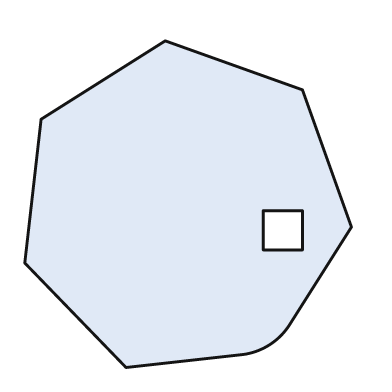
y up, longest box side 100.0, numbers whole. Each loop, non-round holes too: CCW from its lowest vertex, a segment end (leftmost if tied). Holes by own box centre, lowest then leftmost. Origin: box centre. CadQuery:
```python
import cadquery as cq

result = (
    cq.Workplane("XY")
    .moveTo(-19.0, -50.0)
    .lineTo(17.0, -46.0)
    .threePointArc((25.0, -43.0), (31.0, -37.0))
    .lineTo(50.0, -7.0)
    .lineTo(35.0, 35.0)
    .lineTo(-7.0, 50.0)
    .lineTo(-45.0, 26.0)
    .lineTo(-50.0, -18.0)
    .close()
    .moveTo(23.0, -14.0)
    .lineTo(35.0, -14.0)
    .lineTo(35.0, -2.0)
    .lineTo(23.0, -2.0)
    .close()
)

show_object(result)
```